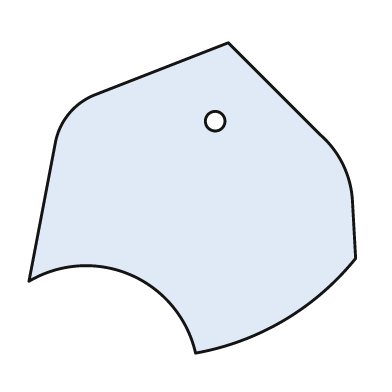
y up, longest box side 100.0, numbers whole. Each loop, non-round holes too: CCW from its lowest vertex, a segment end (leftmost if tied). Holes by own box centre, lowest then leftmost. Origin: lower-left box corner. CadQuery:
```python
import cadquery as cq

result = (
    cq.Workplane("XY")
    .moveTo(51.0, 0.0)
    .threePointArc((78.0, 10.0), (100.0, 29.0))
    .lineTo(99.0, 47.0)
    .threePointArc((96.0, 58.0), (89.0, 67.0))
    .lineTo(61.0, 95.0)
    .lineTo(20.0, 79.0)
    .threePointArc((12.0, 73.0), (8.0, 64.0))
    .lineTo(0.0, 22.0)
    .threePointArc((31.0, 24.0), (51.0, 0.0))
    .close()
    .moveTo(57.0, 71.0)
    .circle(3.0)
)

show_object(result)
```